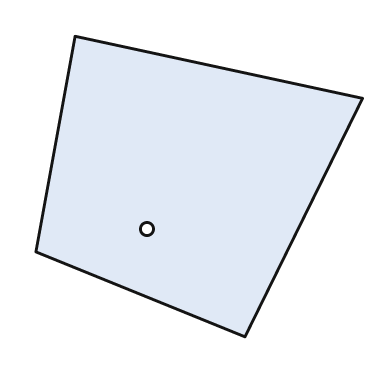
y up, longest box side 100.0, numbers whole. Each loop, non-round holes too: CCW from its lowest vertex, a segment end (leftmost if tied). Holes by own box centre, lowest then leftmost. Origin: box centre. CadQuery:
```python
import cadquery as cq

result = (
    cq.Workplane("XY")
    .moveTo(14.0, -46.0)
    .lineTo(50.0, 27.0)
    .lineTo(-38.0, 46.0)
    .lineTo(-50.0, -20.0)
    .close()
    .moveTo(-16.0, -13.0)
    .circle(2.0)
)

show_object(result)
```